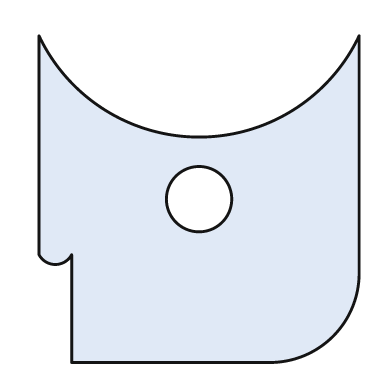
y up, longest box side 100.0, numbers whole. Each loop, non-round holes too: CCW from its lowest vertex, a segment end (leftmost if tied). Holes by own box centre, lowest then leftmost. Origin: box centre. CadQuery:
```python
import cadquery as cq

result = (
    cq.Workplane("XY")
    .moveTo(-39.0, -50.0)
    .lineTo(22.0, -50.0)
    .threePointArc((41.0, -42.0), (49.0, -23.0))
    .lineTo(49.0, 50.0)
    .threePointArc((0.0, 19.0), (-49.0, 50.0))
    .lineTo(-49.0, -17.0)
    .threePointArc((-44.0, -20.0), (-39.0, -17.0))
    .close()
    .moveTo(0.0, 0.0)
    .circle(10.0)
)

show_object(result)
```